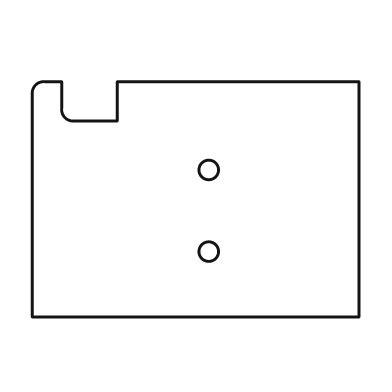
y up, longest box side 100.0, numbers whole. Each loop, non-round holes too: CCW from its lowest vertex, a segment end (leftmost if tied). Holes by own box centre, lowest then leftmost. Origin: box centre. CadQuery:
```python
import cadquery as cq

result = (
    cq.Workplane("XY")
    .moveTo(-50.0, -36.0)
    .lineTo(50.0, -36.0)
    .lineTo(50.0, 36.0)
    .lineTo(-24.0, 36.0)
    .lineTo(-24.0, 24.0)
    .lineTo(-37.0, 24.0)
    .threePointArc((-40.0, 25.0), (-41.0, 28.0))
    .lineTo(-41.0, 36.0)
    .lineTo(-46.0, 36.0)
    .threePointArc((-49.0, 35.0), (-50.0, 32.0))
    .close()
    .moveTo(4.0, -16.0)
    .circle(3.0)
    .moveTo(4.0, 9.0)
    .circle(3.0)
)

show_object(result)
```